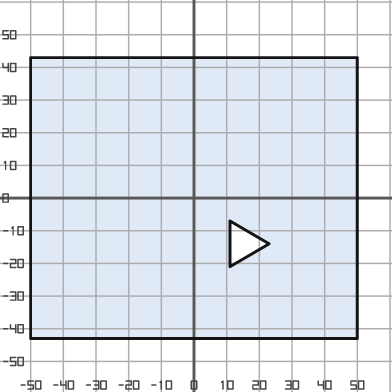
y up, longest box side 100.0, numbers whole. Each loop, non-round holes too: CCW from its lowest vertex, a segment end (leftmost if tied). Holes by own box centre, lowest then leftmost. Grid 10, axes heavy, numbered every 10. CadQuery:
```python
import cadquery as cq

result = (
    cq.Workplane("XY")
    .moveTo(-50.0, -43.0)
    .lineTo(50.0, -43.0)
    .lineTo(50.0, 43.0)
    .lineTo(-50.0, 43.0)
    .close()
    .moveTo(11.0, -21.0)
    .lineTo(23.0, -14.0)
    .lineTo(11.0, -7.0)
    .close()
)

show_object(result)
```